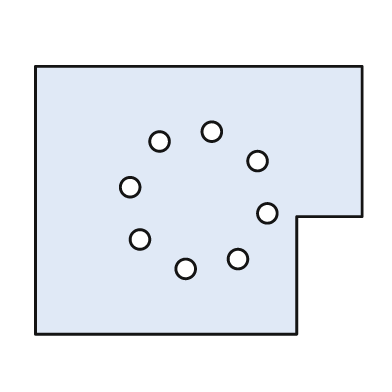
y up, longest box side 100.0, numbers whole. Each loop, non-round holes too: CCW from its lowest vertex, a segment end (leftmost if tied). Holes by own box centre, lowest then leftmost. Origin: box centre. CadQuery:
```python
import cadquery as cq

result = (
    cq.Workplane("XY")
    .moveTo(-50.0, -41.0)
    .lineTo(30.0, -41.0)
    .lineTo(30.0, -5.0)
    .lineTo(50.0, -5.0)
    .lineTo(50.0, 41.0)
    .lineTo(-50.0, 41.0)
    .close()
    .moveTo(-4.0, -21.0)
    .circle(3.0)
    .moveTo(12.0, -18.0)
    .circle(3.0)
    .moveTo(-18.0, -12.0)
    .circle(3.0)
    .moveTo(21.0, -4.0)
    .circle(3.0)
    .moveTo(-21.0, 4.0)
    .circle(3.0)
    .moveTo(18.0, 12.0)
    .circle(3.0)
    .moveTo(-12.0, 18.0)
    .circle(3.0)
    .moveTo(4.0, 21.0)
    .circle(3.0)
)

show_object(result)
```